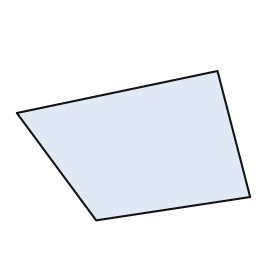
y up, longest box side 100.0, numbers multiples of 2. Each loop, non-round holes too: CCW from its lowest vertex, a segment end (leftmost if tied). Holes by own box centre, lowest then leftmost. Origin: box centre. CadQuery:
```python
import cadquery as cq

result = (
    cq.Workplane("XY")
    .moveTo(-16.0, -32.0)
    .lineTo(50.0, -22.0)
    .lineTo(36.0, 32.0)
    .lineTo(-50.0, 14.0)
    .close()
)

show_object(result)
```